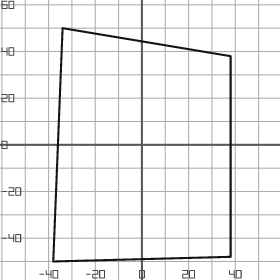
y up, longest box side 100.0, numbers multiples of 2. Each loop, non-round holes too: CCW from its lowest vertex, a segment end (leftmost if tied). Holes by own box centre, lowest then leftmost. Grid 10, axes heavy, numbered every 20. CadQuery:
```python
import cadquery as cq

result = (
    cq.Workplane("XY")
    .moveTo(-38.0, -50.0)
    .lineTo(38.0, -48.0)
    .lineTo(38.0, 38.0)
    .lineTo(-34.0, 50.0)
    .close()
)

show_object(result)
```